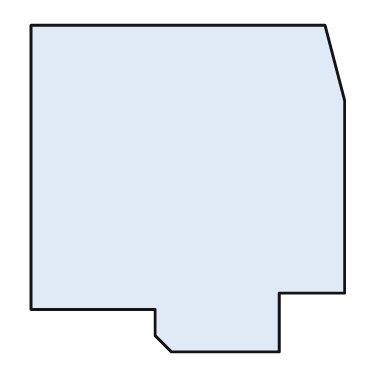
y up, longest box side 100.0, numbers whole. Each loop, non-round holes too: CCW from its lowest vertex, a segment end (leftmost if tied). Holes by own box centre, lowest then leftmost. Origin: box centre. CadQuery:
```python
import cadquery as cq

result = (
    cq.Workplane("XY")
    .moveTo(-5.0, -50.0)
    .lineTo(28.0, -50.0)
    .lineTo(28.0, -32.0)
    .lineTo(48.0, -32.0)
    .lineTo(48.0, 27.0)
    .lineTo(42.0, 50.0)
    .lineTo(-48.0, 50.0)
    .lineTo(-48.0, -37.0)
    .lineTo(-10.0, -37.0)
    .lineTo(-10.0, -45.0)
    .close()
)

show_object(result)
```